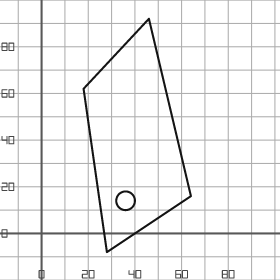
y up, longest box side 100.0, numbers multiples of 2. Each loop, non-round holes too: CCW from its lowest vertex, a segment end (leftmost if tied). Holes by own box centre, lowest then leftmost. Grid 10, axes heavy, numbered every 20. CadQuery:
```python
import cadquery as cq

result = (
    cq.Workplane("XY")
    .moveTo(28.0, -8.0)
    .lineTo(64.0, 16.0)
    .lineTo(46.0, 92.0)
    .lineTo(18.0, 62.0)
    .close()
    .moveTo(36.0, 14.0)
    .circle(4.0)
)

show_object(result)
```